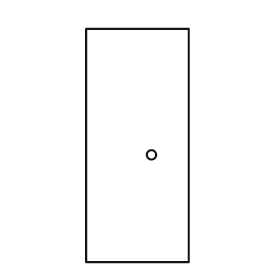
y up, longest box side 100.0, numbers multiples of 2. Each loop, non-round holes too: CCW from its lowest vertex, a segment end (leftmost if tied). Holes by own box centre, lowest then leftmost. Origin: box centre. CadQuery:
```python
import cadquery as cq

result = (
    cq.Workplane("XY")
    .moveTo(-22.0, -50.0)
    .lineTo(22.0, -50.0)
    .lineTo(22.0, 50.0)
    .lineTo(-22.0, 50.0)
    .close()
    .moveTo(6.0, -4.0)
    .circle(2.0)
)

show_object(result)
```